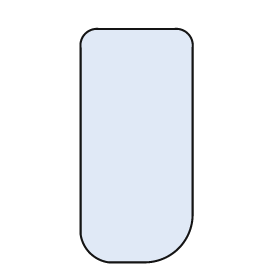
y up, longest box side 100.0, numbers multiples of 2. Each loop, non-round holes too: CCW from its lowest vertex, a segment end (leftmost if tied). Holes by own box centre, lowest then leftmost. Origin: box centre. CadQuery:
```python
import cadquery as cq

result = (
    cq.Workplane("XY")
    .moveTo(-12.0, -50.0)
    .lineTo(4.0, -50.0)
    .threePointArc((18.0, -44.0), (24.0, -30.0))
    .lineTo(24.0, 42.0)
    .threePointArc((22.0, 48.0), (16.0, 50.0))
    .lineTo(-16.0, 50.0)
    .threePointArc((-22.0, 48.0), (-24.0, 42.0))
    .lineTo(-24.0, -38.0)
    .threePointArc((-20.0, -46.0), (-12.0, -50.0))
    .close()
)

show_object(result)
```